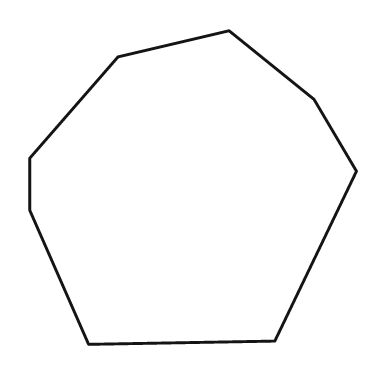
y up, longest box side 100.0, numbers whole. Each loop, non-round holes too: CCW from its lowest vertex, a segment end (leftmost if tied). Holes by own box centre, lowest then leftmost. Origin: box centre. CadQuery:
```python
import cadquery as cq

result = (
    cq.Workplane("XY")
    .moveTo(-32.0, -48.0)
    .lineTo(25.0, -47.0)
    .lineTo(50.0, 5.0)
    .lineTo(37.0, 27.0)
    .lineTo(11.0, 48.0)
    .lineTo(-23.0, 40.0)
    .lineTo(-50.0, 9.0)
    .lineTo(-50.0, -7.0)
    .close()
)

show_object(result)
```